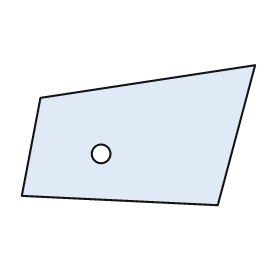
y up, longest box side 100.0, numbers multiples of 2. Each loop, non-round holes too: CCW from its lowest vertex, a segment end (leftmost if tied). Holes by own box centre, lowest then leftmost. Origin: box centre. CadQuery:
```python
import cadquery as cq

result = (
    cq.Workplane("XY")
    .moveTo(34.0, -30.0)
    .lineTo(50.0, 30.0)
    .lineTo(-42.0, 16.0)
    .lineTo(-50.0, -26.0)
    .close()
    .moveTo(-16.0, -8.0)
    .circle(4.0)
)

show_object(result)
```